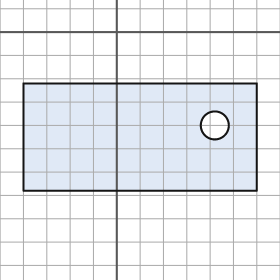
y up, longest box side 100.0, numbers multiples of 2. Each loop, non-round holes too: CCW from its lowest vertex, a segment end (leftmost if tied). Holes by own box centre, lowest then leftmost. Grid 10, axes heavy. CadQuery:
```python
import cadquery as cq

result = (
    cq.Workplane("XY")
    .moveTo(-40.0, -68.0)
    .lineTo(60.0, -68.0)
    .lineTo(60.0, -22.0)
    .lineTo(-40.0, -22.0)
    .close()
    .moveTo(42.0, -40.0)
    .circle(6.0)
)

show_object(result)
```